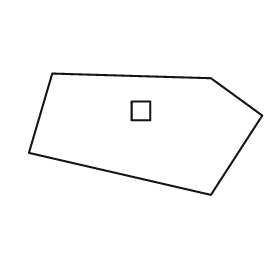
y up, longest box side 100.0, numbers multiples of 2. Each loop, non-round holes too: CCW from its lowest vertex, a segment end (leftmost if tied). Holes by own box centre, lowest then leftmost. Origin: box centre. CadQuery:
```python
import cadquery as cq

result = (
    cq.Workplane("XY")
    .moveTo(28.0, -26.0)
    .lineTo(50.0, 8.0)
    .lineTo(28.0, 24.0)
    .lineTo(-40.0, 26.0)
    .lineTo(-50.0, -8.0)
    .close()
    .moveTo(-6.0, 6.0)
    .lineTo(2.0, 6.0)
    .lineTo(2.0, 14.0)
    .lineTo(-6.0, 14.0)
    .close()
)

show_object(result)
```